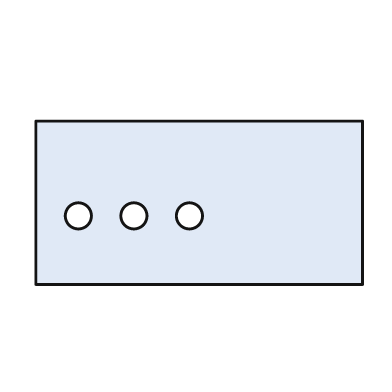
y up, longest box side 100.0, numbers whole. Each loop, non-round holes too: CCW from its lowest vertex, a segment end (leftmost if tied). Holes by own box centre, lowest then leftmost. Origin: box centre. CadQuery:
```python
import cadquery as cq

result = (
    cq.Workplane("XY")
    .moveTo(-50.0, -25.0)
    .lineTo(50.0, -25.0)
    .lineTo(50.0, 25.0)
    .lineTo(-50.0, 25.0)
    .close()
    .moveTo(-37.0, -4.0)
    .circle(4.0)
    .moveTo(-20.0, -4.0)
    .circle(4.0)
    .moveTo(-3.0, -4.0)
    .circle(4.0)
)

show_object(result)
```